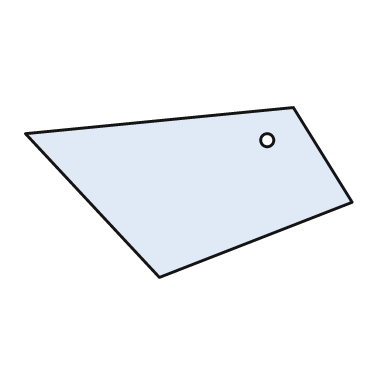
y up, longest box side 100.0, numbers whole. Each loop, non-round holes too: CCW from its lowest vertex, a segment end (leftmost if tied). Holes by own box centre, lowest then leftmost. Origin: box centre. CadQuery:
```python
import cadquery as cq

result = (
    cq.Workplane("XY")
    .moveTo(-9.0, -26.0)
    .lineTo(50.0, -3.0)
    .lineTo(32.0, 26.0)
    .lineTo(-50.0, 18.0)
    .close()
    .moveTo(24.0, 16.0)
    .circle(2.0)
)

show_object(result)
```